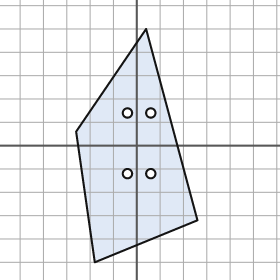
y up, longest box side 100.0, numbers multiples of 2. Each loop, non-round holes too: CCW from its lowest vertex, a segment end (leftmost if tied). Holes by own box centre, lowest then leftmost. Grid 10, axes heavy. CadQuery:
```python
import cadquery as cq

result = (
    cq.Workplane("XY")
    .moveTo(-18.0, -50.0)
    .lineTo(26.0, -32.0)
    .lineTo(4.0, 50.0)
    .lineTo(-26.0, 6.0)
    .close()
    .moveTo(-4.0, -12.0)
    .circle(2.0)
    .moveTo(6.0, -12.0)
    .circle(2.0)
    .moveTo(-4.0, 14.0)
    .circle(2.0)
    .moveTo(6.0, 14.0)
    .circle(2.0)
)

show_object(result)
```